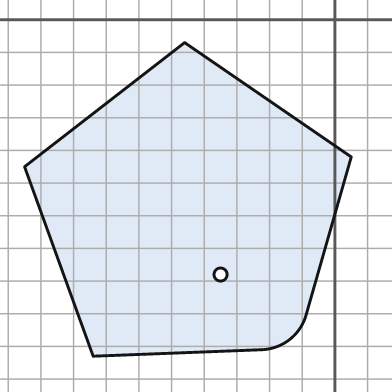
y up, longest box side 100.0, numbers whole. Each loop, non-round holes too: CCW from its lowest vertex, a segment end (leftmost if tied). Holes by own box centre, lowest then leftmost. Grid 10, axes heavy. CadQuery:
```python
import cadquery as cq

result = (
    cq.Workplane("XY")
    .moveTo(-74.0, -103.0)
    .lineTo(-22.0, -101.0)
    .threePointArc((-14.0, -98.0), (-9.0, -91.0))
    .lineTo(5.0, -42.0)
    .lineTo(-46.0, -7.0)
    .lineTo(-95.0, -45.0)
    .close()
    .moveTo(-35.0, -78.0)
    .circle(2.0)
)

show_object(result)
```